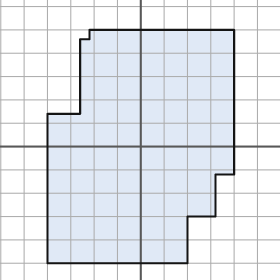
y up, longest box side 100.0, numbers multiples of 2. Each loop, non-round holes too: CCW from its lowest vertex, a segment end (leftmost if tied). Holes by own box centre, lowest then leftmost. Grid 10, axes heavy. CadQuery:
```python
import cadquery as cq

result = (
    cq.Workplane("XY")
    .moveTo(-40.0, -50.0)
    .lineTo(20.0, -50.0)
    .lineTo(20.0, -30.0)
    .lineTo(32.0, -30.0)
    .lineTo(32.0, -12.0)
    .lineTo(40.0, -12.0)
    .lineTo(40.0, 50.0)
    .lineTo(-22.0, 50.0)
    .lineTo(-22.0, 46.0)
    .lineTo(-26.0, 46.0)
    .lineTo(-26.0, 14.0)
    .lineTo(-40.0, 14.0)
    .close()
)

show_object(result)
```